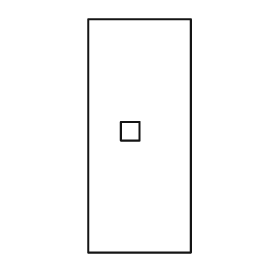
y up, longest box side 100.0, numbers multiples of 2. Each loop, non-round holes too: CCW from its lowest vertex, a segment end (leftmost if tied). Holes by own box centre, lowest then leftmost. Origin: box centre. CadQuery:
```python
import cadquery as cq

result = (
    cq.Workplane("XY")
    .moveTo(-22.0, -50.0)
    .lineTo(22.0, -50.0)
    .lineTo(22.0, 50.0)
    .lineTo(-22.0, 50.0)
    .close()
    .moveTo(-8.0, -2.0)
    .lineTo(0.0, -2.0)
    .lineTo(0.0, 6.0)
    .lineTo(-8.0, 6.0)
    .close()
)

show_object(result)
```